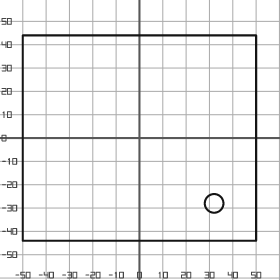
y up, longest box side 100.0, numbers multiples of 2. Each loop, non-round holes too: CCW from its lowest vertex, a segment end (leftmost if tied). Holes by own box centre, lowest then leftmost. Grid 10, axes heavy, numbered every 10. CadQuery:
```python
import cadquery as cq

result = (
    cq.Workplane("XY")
    .moveTo(-50.0, -44.0)
    .lineTo(50.0, -44.0)
    .lineTo(50.0, 44.0)
    .lineTo(-50.0, 44.0)
    .close()
    .moveTo(32.0, -28.0)
    .circle(4.0)
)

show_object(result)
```